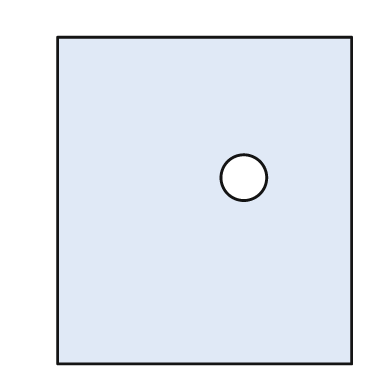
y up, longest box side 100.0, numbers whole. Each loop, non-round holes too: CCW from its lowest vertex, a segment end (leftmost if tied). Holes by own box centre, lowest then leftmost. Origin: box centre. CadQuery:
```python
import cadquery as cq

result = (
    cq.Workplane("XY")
    .moveTo(-45.0, -50.0)
    .lineTo(45.0, -50.0)
    .lineTo(45.0, 50.0)
    .lineTo(-45.0, 50.0)
    .close()
    .moveTo(12.0, 7.0)
    .circle(7.0)
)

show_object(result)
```